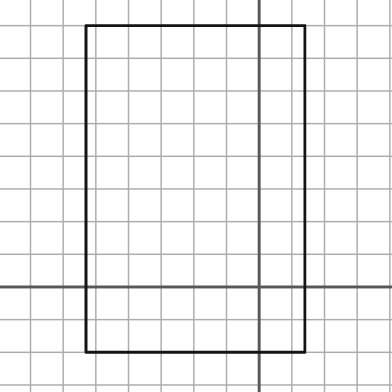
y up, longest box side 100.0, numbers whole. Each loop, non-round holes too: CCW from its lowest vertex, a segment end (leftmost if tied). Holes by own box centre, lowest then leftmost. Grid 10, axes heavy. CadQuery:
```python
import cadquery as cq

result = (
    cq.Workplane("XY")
    .moveTo(-53.0, -20.0)
    .lineTo(14.0, -20.0)
    .lineTo(14.0, 80.0)
    .lineTo(-53.0, 80.0)
    .close()
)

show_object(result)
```